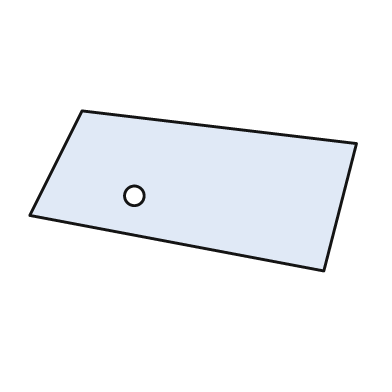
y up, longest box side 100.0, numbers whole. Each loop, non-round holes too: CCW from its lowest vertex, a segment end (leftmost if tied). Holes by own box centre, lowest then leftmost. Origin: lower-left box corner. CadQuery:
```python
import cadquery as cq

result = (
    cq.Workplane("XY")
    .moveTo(90.0, 0.0)
    .lineTo(100.0, 39.0)
    .lineTo(16.0, 49.0)
    .lineTo(0.0, 17.0)
    .close()
    .moveTo(32.0, 23.0)
    .circle(3.0)
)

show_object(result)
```